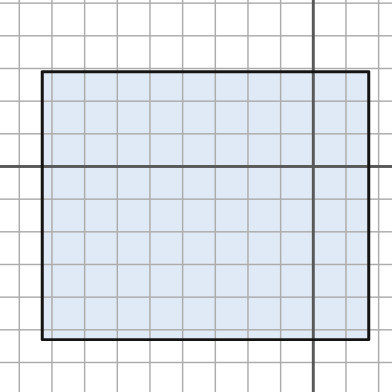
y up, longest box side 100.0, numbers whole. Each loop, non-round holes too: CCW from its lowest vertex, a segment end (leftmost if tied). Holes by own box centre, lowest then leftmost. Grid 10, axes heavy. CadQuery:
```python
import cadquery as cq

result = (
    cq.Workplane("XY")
    .moveTo(-83.0, -53.0)
    .lineTo(17.0, -53.0)
    .lineTo(17.0, 29.0)
    .lineTo(-83.0, 29.0)
    .close()
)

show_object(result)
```